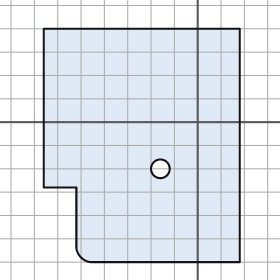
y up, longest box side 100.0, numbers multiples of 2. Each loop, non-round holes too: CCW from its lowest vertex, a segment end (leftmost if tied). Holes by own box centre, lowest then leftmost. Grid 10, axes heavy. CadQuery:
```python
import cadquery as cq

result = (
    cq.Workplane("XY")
    .moveTo(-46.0, -60.0)
    .lineTo(18.0, -60.0)
    .lineTo(18.0, 40.0)
    .lineTo(-66.0, 40.0)
    .lineTo(-66.0, -28.0)
    .lineTo(-52.0, -28.0)
    .lineTo(-52.0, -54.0)
    .threePointArc((-50.0, -58.0), (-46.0, -60.0))
    .close()
    .moveTo(-16.0, -20.0)
    .circle(4.0)
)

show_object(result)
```